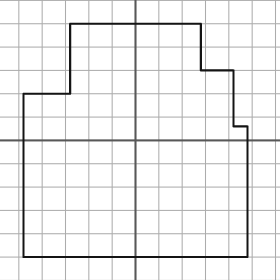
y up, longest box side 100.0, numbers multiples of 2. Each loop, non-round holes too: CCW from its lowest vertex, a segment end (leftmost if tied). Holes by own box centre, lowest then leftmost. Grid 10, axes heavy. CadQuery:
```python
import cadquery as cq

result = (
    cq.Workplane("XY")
    .moveTo(-48.0, -50.0)
    .lineTo(48.0, -50.0)
    .lineTo(48.0, 6.0)
    .lineTo(42.0, 6.0)
    .lineTo(42.0, 30.0)
    .lineTo(28.0, 30.0)
    .lineTo(28.0, 50.0)
    .lineTo(-28.0, 50.0)
    .lineTo(-28.0, 20.0)
    .lineTo(-48.0, 20.0)
    .close()
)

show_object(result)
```